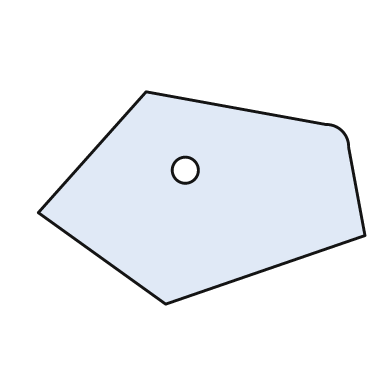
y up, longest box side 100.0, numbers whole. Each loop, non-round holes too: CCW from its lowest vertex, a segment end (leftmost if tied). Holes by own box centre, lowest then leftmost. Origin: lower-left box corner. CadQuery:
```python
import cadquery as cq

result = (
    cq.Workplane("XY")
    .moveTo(39.0, 0.0)
    .lineTo(100.0, 21.0)
    .lineTo(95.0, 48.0)
    .threePointArc((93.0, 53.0), (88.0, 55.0))
    .lineTo(33.0, 65.0)
    .lineTo(0.0, 28.0)
    .close()
    .moveTo(45.0, 41.0)
    .circle(4.0)
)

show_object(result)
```